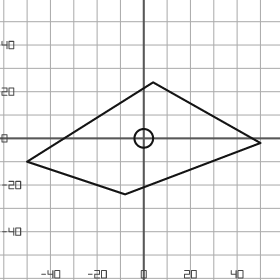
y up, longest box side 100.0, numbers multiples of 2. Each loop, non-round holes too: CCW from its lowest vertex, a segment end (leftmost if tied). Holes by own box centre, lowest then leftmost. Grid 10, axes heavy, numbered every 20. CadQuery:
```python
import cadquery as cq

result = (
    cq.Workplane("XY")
    .moveTo(-8.0, -24.0)
    .lineTo(50.0, -2.0)
    .lineTo(4.0, 24.0)
    .lineTo(-50.0, -10.0)
    .close()
    .moveTo(0.0, 0.0)
    .circle(4.0)
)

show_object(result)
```